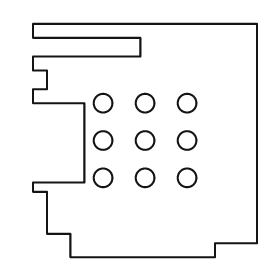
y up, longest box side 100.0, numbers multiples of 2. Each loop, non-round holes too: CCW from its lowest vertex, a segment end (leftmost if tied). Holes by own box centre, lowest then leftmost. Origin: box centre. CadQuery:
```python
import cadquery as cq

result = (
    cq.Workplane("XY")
    .moveTo(-32.0, -50.0)
    .lineTo(30.0, -50.0)
    .lineTo(30.0, -44.0)
    .lineTo(48.0, -44.0)
    .lineTo(48.0, 50.0)
    .lineTo(-48.0, 50.0)
    .lineTo(-48.0, 44.0)
    .lineTo(-2.0, 44.0)
    .lineTo(-2.0, 36.0)
    .lineTo(-48.0, 36.0)
    .lineTo(-48.0, 30.0)
    .lineTo(-42.0, 30.0)
    .lineTo(-42.0, 22.0)
    .lineTo(-48.0, 22.0)
    .lineTo(-48.0, 16.0)
    .lineTo(-26.0, 16.0)
    .lineTo(-26.0, -18.0)
    .lineTo(-48.0, -18.0)
    .lineTo(-48.0, -22.0)
    .lineTo(-42.0, -22.0)
    .lineTo(-42.0, -40.0)
    .lineTo(-32.0, -40.0)
    .close()
    .moveTo(-18.0, -16.0)
    .circle(4.0)
    .moveTo(0.0, -16.0)
    .circle(4.0)
    .moveTo(18.0, -16.0)
    .circle(4.0)
    .moveTo(-18.0, 0.0)
    .circle(4.0)
    .moveTo(0.0, 0.0)
    .circle(4.0)
    .moveTo(18.0, 0.0)
    .circle(4.0)
    .moveTo(-18.0, 16.0)
    .circle(4.0)
    .moveTo(0.0, 16.0)
    .circle(4.0)
    .moveTo(18.0, 16.0)
    .circle(4.0)
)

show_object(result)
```